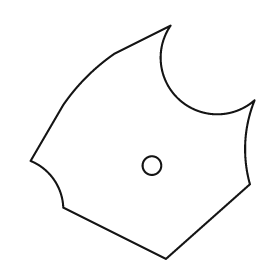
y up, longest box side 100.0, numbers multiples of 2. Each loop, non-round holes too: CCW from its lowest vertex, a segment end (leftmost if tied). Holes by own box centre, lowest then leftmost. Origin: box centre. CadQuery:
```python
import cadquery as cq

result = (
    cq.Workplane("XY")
    .moveTo(10.0, -50.0)
    .lineTo(46.0, -18.0)
    .threePointArc((44.0, 0.0), (48.0, 18.0))
    .threePointArc((16.0, 18.0), (12.0, 50.0))
    .lineTo(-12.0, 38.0)
    .threePointArc((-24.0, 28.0), (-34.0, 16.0))
    .lineTo(-48.0, -8.0)
    .threePointArc((-38.0, -16.0), (-34.0, -28.0))
    .close()
    .moveTo(4.0, -10.0)
    .circle(4.0)
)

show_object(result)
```